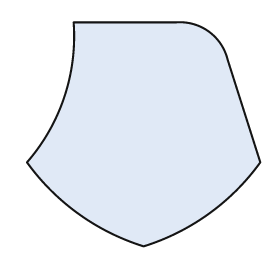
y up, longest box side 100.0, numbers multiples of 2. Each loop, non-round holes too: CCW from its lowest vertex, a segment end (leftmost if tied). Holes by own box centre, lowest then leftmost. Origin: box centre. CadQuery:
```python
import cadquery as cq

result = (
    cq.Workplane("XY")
    .moveTo(0.0, -48.0)
    .threePointArc((28.0, -34.0), (50.0, -12.0))
    .lineTo(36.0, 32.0)
    .threePointArc((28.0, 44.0), (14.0, 48.0))
    .lineTo(-30.0, 48.0)
    .threePointArc((-34.0, 16.0), (-50.0, -12.0))
    .threePointArc((-28.0, -34.0), (0.0, -48.0))
    .close()
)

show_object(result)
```